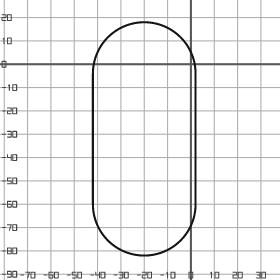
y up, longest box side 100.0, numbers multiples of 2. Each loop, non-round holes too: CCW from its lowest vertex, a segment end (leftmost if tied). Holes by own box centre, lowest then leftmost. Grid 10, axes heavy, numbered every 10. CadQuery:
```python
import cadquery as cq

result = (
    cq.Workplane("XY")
    .moveTo(-42.0, -60.0)
    .threePointArc((-20.0, -82.0), (2.0, -60.0))
    .lineTo(2.0, -4.0)
    .threePointArc((-20.0, 18.0), (-42.0, -4.0))
    .close()
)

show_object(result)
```